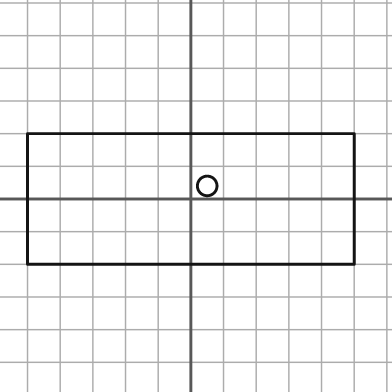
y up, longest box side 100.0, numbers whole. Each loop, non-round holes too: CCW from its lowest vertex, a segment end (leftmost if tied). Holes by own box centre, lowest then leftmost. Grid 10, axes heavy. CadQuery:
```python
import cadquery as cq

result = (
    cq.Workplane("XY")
    .moveTo(-50.0, -20.0)
    .lineTo(50.0, -20.0)
    .lineTo(50.0, 20.0)
    .lineTo(-50.0, 20.0)
    .close()
    .moveTo(5.0, 4.0)
    .circle(3.0)
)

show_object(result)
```